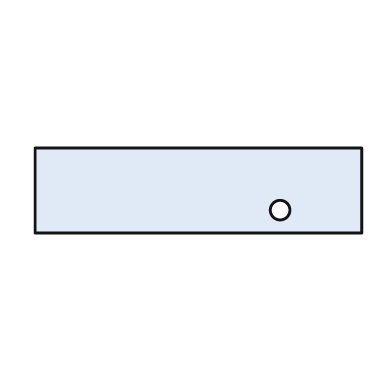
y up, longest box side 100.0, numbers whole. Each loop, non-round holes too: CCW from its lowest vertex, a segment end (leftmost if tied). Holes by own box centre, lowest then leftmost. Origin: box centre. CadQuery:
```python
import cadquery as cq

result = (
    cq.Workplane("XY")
    .moveTo(-50.0, -13.0)
    .lineTo(50.0, -13.0)
    .lineTo(50.0, 13.0)
    .lineTo(-50.0, 13.0)
    .close()
    .moveTo(25.0, -6.0)
    .circle(3.0)
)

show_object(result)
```